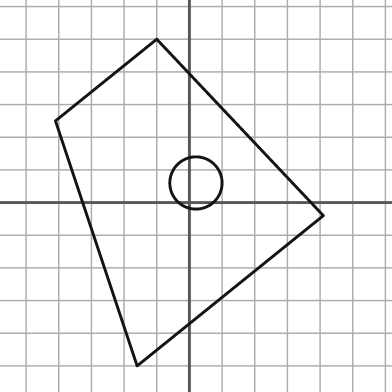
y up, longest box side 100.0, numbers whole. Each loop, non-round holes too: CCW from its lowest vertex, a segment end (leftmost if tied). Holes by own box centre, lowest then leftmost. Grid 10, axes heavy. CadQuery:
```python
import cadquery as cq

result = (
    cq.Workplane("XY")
    .moveTo(-16.0, -50.0)
    .lineTo(41.0, -4.0)
    .lineTo(-10.0, 50.0)
    .lineTo(-41.0, 25.0)
    .close()
    .moveTo(2.0, 6.0)
    .circle(8.0)
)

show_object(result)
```